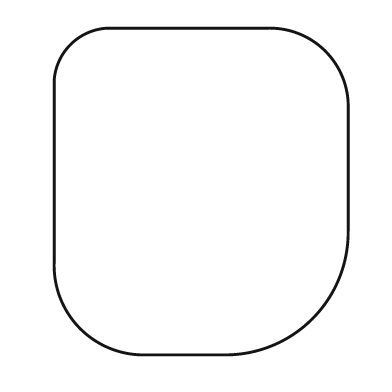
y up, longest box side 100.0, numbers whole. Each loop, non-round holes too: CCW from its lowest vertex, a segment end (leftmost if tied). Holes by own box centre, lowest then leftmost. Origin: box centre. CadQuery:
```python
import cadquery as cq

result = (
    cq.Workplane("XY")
    .moveTo(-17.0, -50.0)
    .lineTo(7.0, -50.0)
    .threePointArc((34.0, -39.0), (45.0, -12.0))
    .lineTo(45.0, 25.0)
    .threePointArc((38.0, 43.0), (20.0, 50.0))
    .lineTo(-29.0, 50.0)
    .threePointArc((-40.0, 45.0), (-45.0, 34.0))
    .lineTo(-45.0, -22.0)
    .threePointArc((-37.0, -42.0), (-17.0, -50.0))
    .close()
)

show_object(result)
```